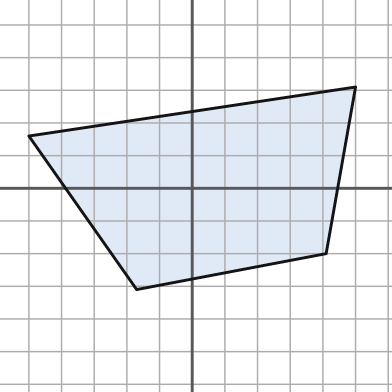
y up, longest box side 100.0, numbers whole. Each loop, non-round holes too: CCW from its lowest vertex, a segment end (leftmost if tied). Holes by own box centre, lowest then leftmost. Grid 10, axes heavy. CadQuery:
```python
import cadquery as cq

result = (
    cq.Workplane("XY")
    .moveTo(-17.0, -31.0)
    .lineTo(41.0, -20.0)
    .lineTo(50.0, 31.0)
    .lineTo(-50.0, 16.0)
    .close()
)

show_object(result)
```